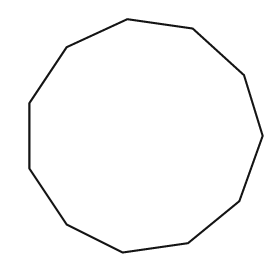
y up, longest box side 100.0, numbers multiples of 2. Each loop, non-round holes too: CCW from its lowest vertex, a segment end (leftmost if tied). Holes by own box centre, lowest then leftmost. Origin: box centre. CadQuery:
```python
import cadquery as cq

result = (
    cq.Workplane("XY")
    .moveTo(-10.0, -50.0)
    .lineTo(18.0, -46.0)
    .lineTo(40.0, -28.0)
    .lineTo(50.0, 0.0)
    .lineTo(42.0, 26.0)
    .lineTo(20.0, 46.0)
    .lineTo(-8.0, 50.0)
    .lineTo(-34.0, 38.0)
    .lineTo(-50.0, 14.0)
    .lineTo(-50.0, -14.0)
    .lineTo(-34.0, -38.0)
    .close()
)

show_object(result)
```